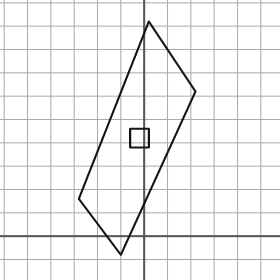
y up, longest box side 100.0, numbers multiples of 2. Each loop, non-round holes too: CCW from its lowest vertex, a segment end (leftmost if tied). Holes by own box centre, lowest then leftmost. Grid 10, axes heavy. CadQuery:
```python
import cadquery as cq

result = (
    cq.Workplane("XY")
    .moveTo(-10.0, -8.0)
    .lineTo(22.0, 62.0)
    .lineTo(2.0, 92.0)
    .lineTo(-28.0, 16.0)
    .close()
    .moveTo(-6.0, 38.0)
    .lineTo(2.0, 38.0)
    .lineTo(2.0, 46.0)
    .lineTo(-6.0, 46.0)
    .close()
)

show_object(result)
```